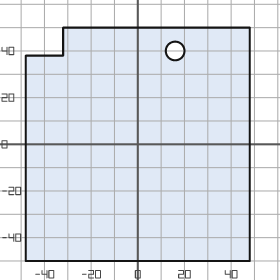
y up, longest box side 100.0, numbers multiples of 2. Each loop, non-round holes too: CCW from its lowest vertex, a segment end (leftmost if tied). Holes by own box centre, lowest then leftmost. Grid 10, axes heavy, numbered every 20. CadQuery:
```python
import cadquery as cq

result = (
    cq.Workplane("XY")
    .moveTo(-48.0, -50.0)
    .lineTo(48.0, -50.0)
    .lineTo(48.0, 50.0)
    .lineTo(-32.0, 50.0)
    .lineTo(-32.0, 38.0)
    .lineTo(-48.0, 38.0)
    .close()
    .moveTo(16.0, 40.0)
    .circle(4.0)
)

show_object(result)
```